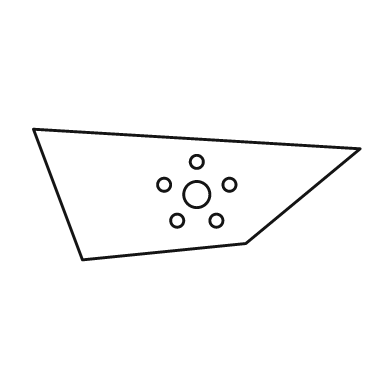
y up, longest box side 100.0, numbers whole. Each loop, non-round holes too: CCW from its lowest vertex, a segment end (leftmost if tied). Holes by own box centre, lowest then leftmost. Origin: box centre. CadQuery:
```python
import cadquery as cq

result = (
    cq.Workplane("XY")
    .moveTo(-35.0, -20.0)
    .lineTo(15.0, -15.0)
    .lineTo(50.0, 14.0)
    .lineTo(-50.0, 20.0)
    .close()
    .moveTo(-6.0, -8.0)
    .circle(2.0)
    .moveTo(6.0, -8.0)
    .circle(2.0)
    .moveTo(0.0, 0.0)
    .circle(4.0)
    .moveTo(-10.0, 3.0)
    .circle(2.0)
    .moveTo(10.0, 3.0)
    .circle(2.0)
    .moveTo(0.0, 10.0)
    .circle(2.0)
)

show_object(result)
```